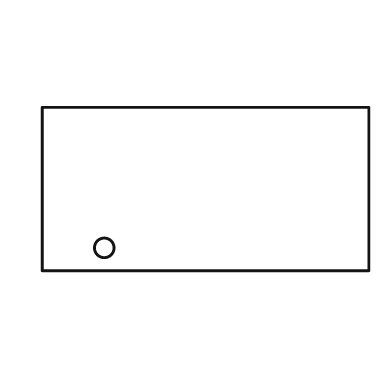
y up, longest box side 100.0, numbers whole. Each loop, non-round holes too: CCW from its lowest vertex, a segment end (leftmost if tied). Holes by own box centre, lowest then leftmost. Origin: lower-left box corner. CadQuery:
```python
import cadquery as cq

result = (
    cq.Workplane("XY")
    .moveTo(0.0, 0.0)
    .lineTo(100.0, 0.0)
    .lineTo(100.0, 50.0)
    .lineTo(0.0, 50.0)
    .close()
    .moveTo(19.0, 7.0)
    .circle(3.0)
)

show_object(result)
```